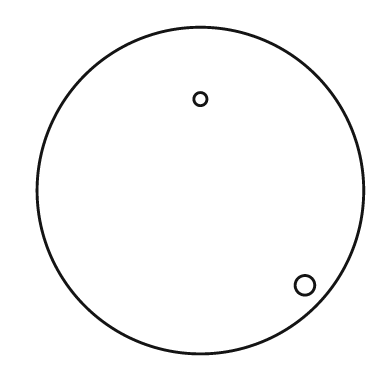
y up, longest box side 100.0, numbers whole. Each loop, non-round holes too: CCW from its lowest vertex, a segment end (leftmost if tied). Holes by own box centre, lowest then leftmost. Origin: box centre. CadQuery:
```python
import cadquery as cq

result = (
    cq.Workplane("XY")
    .moveTo(0.0, 0.0)
    .circle(50.0)
    .moveTo(32.0, -29.0)
    .circle(3.0)
    .moveTo(0.0, 28.0)
    .circle(2.0)
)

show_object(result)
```